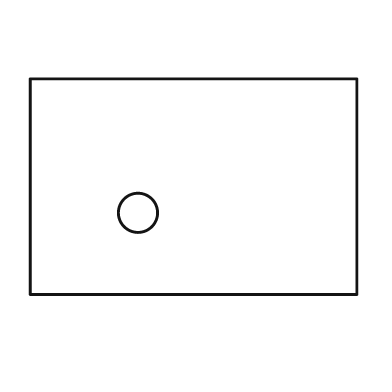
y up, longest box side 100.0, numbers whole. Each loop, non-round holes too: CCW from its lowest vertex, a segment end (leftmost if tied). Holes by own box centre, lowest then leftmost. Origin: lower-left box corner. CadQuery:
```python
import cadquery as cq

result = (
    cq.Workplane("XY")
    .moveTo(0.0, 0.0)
    .lineTo(100.0, 0.0)
    .lineTo(100.0, 66.0)
    .lineTo(0.0, 66.0)
    .close()
    .moveTo(33.0, 25.0)
    .circle(6.0)
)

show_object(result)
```